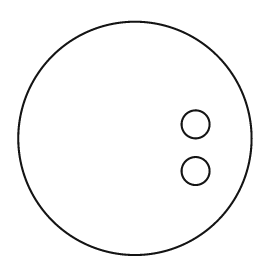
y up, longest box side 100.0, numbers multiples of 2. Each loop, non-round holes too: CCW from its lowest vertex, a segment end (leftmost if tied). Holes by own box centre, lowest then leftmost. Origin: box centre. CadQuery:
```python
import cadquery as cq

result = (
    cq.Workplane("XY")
    .moveTo(0.0, 0.0)
    .circle(50.0)
    .moveTo(26.0, -14.0)
    .circle(6.0)
    .moveTo(26.0, 6.0)
    .circle(6.0)
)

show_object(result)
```